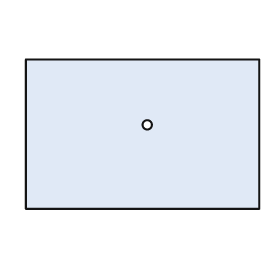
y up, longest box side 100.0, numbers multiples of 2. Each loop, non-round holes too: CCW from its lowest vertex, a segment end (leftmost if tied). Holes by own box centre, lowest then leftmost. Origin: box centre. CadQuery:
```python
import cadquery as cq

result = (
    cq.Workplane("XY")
    .moveTo(-50.0, -32.0)
    .lineTo(50.0, -32.0)
    .lineTo(50.0, 32.0)
    .lineTo(-50.0, 32.0)
    .close()
    .moveTo(2.0, 4.0)
    .circle(2.0)
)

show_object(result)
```